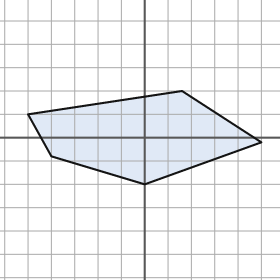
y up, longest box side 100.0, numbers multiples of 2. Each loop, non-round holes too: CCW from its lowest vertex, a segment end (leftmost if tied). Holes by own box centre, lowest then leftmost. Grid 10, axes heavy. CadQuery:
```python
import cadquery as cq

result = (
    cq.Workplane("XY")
    .moveTo(0.0, -20.0)
    .lineTo(50.0, -2.0)
    .lineTo(16.0, 20.0)
    .lineTo(-50.0, 10.0)
    .lineTo(-40.0, -8.0)
    .close()
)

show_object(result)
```